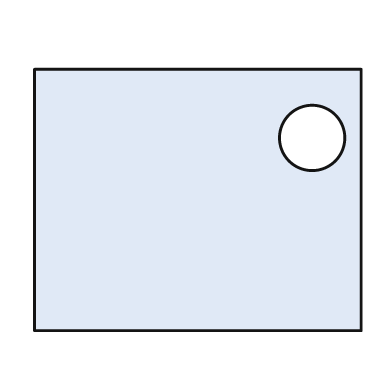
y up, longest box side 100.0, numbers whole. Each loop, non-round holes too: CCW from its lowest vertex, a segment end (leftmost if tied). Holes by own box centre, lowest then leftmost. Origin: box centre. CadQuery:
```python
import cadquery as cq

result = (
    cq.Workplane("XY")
    .moveTo(-50.0, -40.0)
    .lineTo(50.0, -40.0)
    .lineTo(50.0, 40.0)
    .lineTo(-50.0, 40.0)
    .close()
    .moveTo(35.0, 19.0)
    .circle(10.0)
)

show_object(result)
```